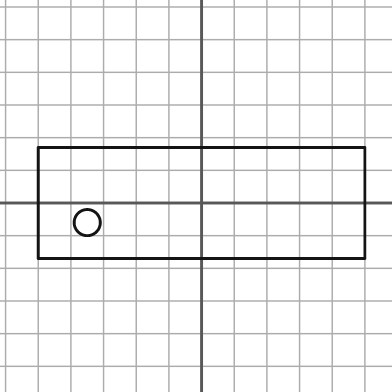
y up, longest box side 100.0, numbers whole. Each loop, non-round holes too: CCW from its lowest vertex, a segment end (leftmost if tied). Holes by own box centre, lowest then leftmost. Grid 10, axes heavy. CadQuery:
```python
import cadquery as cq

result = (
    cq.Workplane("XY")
    .moveTo(-50.0, -17.0)
    .lineTo(50.0, -17.0)
    .lineTo(50.0, 17.0)
    .lineTo(-50.0, 17.0)
    .close()
    .moveTo(-35.0, -6.0)
    .circle(4.0)
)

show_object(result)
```